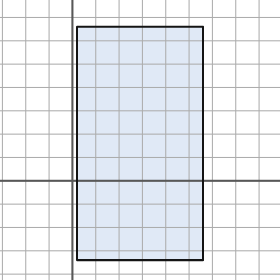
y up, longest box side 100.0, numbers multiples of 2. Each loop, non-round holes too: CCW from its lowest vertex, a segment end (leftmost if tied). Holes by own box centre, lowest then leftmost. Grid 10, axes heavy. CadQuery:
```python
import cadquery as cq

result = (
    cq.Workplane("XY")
    .moveTo(2.0, -34.0)
    .lineTo(56.0, -34.0)
    .lineTo(56.0, 66.0)
    .lineTo(2.0, 66.0)
    .close()
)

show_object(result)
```